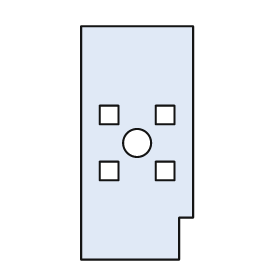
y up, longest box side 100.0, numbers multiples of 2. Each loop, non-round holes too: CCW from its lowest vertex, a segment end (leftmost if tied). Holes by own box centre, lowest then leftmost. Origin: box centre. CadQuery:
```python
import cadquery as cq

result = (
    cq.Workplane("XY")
    .moveTo(-24.0, -50.0)
    .lineTo(18.0, -50.0)
    .lineTo(18.0, -32.0)
    .lineTo(24.0, -32.0)
    .lineTo(24.0, 50.0)
    .lineTo(-24.0, 50.0)
    .close()
    .moveTo(-16.0, -16.0)
    .lineTo(-8.0, -16.0)
    .lineTo(-8.0, -8.0)
    .lineTo(-16.0, -8.0)
    .close()
    .moveTo(8.0, -16.0)
    .lineTo(16.0, -16.0)
    .lineTo(16.0, -8.0)
    .lineTo(8.0, -8.0)
    .close()
    .moveTo(0.0, 0.0)
    .circle(6.0)
    .moveTo(-16.0, 8.0)
    .lineTo(-8.0, 8.0)
    .lineTo(-8.0, 16.0)
    .lineTo(-16.0, 16.0)
    .close()
    .moveTo(8.0, 8.0)
    .lineTo(16.0, 8.0)
    .lineTo(16.0, 16.0)
    .lineTo(8.0, 16.0)
    .close()
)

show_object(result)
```